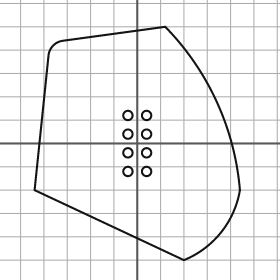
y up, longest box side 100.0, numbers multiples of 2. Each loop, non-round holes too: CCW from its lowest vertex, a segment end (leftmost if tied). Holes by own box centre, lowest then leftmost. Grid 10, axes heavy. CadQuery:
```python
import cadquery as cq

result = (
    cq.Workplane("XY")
    .moveTo(20.0, -50.0)
    .threePointArc((36.0, -38.0), (44.0, -20.0))
    .threePointArc((34.0, 18.0), (12.0, 50.0))
    .lineTo(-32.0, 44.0)
    .threePointArc((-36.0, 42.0), (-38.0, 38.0))
    .lineTo(-44.0, -20.0)
    .close()
    .moveTo(-4.0, -12.0)
    .circle(2.0)
    .moveTo(4.0, -12.0)
    .circle(2.0)
    .moveTo(-4.0, -4.0)
    .circle(2.0)
    .moveTo(4.0, -4.0)
    .circle(2.0)
    .moveTo(-4.0, 4.0)
    .circle(2.0)
    .moveTo(4.0, 4.0)
    .circle(2.0)
    .moveTo(-4.0, 12.0)
    .circle(2.0)
    .moveTo(4.0, 12.0)
    .circle(2.0)
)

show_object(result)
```